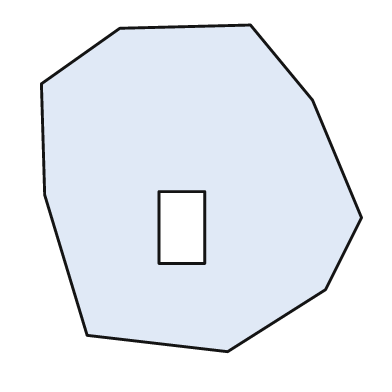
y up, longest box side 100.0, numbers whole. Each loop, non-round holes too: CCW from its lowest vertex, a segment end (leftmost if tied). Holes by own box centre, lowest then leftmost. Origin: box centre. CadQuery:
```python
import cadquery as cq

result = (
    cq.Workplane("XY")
    .moveTo(8.0, -50.0)
    .lineTo(38.0, -31.0)
    .lineTo(49.0, -9.0)
    .lineTo(34.0, 27.0)
    .lineTo(15.0, 50.0)
    .lineTo(-25.0, 49.0)
    .lineTo(-49.0, 32.0)
    .lineTo(-48.0, -2.0)
    .lineTo(-35.0, -45.0)
    .close()
    .moveTo(-13.0, -23.0)
    .lineTo(1.0, -23.0)
    .lineTo(1.0, -1.0)
    .lineTo(-13.0, -1.0)
    .close()
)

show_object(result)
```